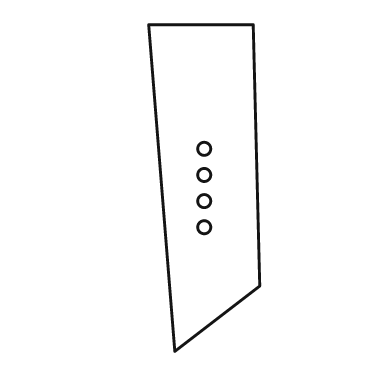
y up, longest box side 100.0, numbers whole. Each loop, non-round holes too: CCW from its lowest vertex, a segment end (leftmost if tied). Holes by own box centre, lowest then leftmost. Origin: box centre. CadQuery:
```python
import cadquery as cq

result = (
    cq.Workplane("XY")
    .moveTo(-9.0, -50.0)
    .lineTo(17.0, -30.0)
    .lineTo(15.0, 50.0)
    .lineTo(-17.0, 50.0)
    .close()
    .moveTo(0.0, -12.0)
    .circle(2.0)
    .moveTo(0.0, -4.0)
    .circle(2.0)
    .moveTo(0.0, 4.0)
    .circle(2.0)
    .moveTo(0.0, 12.0)
    .circle(2.0)
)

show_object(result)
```